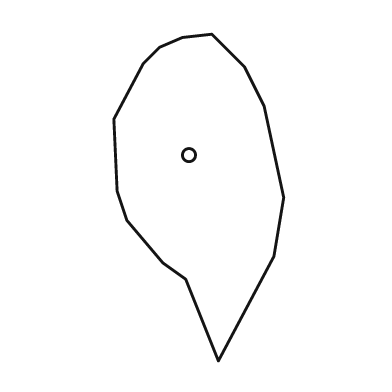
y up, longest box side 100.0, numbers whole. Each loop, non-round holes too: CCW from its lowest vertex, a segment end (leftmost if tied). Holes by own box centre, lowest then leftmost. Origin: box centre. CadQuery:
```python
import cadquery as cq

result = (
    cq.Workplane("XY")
    .moveTo(6.0, -50.0)
    .lineTo(23.0, -18.0)
    .lineTo(26.0, 0.0)
    .lineTo(20.0, 28.0)
    .lineTo(14.0, 40.0)
    .lineTo(4.0, 50.0)
    .lineTo(-5.0, 49.0)
    .lineTo(-12.0, 46.0)
    .lineTo(-17.0, 41.0)
    .lineTo(-26.0, 24.0)
    .lineTo(-25.0, 2.0)
    .lineTo(-22.0, -7.0)
    .lineTo(-11.0, -20.0)
    .lineTo(-4.0, -25.0)
    .close()
    .moveTo(-3.0, 13.0)
    .circle(2.0)
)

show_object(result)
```